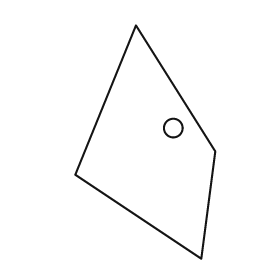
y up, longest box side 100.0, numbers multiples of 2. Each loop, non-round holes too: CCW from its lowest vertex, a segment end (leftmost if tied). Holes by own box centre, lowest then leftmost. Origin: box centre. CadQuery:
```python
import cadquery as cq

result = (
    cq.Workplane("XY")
    .moveTo(24.0, -50.0)
    .lineTo(30.0, -4.0)
    .lineTo(-4.0, 50.0)
    .lineTo(-30.0, -14.0)
    .close()
    .moveTo(12.0, 6.0)
    .circle(4.0)
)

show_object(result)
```